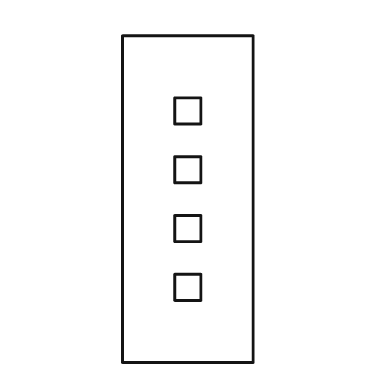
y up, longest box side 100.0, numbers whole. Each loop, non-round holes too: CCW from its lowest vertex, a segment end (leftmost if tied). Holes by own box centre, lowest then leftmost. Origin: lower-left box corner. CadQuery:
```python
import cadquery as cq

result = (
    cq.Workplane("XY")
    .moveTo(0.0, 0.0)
    .lineTo(40.0, 0.0)
    .lineTo(40.0, 100.0)
    .lineTo(0.0, 100.0)
    .close()
    .moveTo(16.0, 19.0)
    .lineTo(24.0, 19.0)
    .lineTo(24.0, 27.0)
    .lineTo(16.0, 27.0)
    .close()
    .moveTo(16.0, 37.0)
    .lineTo(24.0, 37.0)
    .lineTo(24.0, 45.0)
    .lineTo(16.0, 45.0)
    .close()
    .moveTo(16.0, 55.0)
    .lineTo(24.0, 55.0)
    .lineTo(24.0, 63.0)
    .lineTo(16.0, 63.0)
    .close()
    .moveTo(16.0, 73.0)
    .lineTo(24.0, 73.0)
    .lineTo(24.0, 81.0)
    .lineTo(16.0, 81.0)
    .close()
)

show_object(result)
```